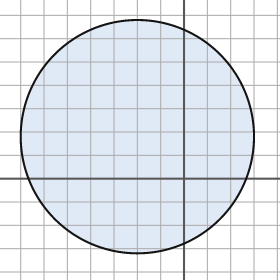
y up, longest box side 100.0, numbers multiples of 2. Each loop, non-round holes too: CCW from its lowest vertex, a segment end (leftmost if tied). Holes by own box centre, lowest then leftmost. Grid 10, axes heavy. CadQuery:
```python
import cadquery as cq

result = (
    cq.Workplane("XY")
    .moveTo(-20.0, 18.0)
    .circle(50.0)
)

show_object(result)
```